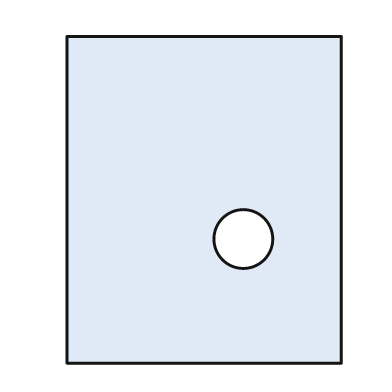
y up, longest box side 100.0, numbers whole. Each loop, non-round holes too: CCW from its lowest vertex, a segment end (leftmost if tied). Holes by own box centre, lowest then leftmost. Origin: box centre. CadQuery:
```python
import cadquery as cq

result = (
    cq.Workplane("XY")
    .moveTo(-42.0, -50.0)
    .lineTo(42.0, -50.0)
    .lineTo(42.0, 50.0)
    .lineTo(-42.0, 50.0)
    .close()
    .moveTo(12.0, -12.0)
    .circle(9.0)
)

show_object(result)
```